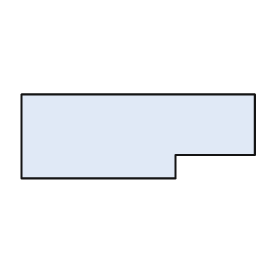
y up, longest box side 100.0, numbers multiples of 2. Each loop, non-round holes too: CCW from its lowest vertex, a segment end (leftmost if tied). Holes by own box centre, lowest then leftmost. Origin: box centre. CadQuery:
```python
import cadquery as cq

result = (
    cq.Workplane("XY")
    .moveTo(-50.0, -18.0)
    .lineTo(16.0, -18.0)
    .lineTo(16.0, -8.0)
    .lineTo(50.0, -8.0)
    .lineTo(50.0, 18.0)
    .lineTo(-50.0, 18.0)
    .close()
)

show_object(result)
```